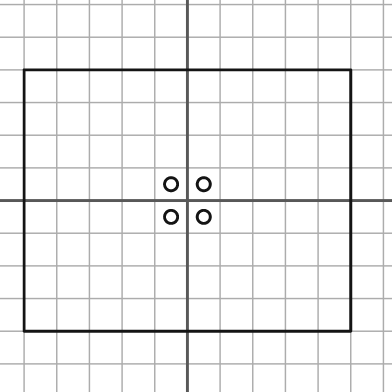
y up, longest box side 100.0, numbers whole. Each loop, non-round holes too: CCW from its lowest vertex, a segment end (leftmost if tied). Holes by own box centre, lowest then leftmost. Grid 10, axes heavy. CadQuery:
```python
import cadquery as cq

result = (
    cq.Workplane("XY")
    .moveTo(-50.0, -40.0)
    .lineTo(50.0, -40.0)
    .lineTo(50.0, 40.0)
    .lineTo(-50.0, 40.0)
    .close()
    .moveTo(-5.0, -5.0)
    .circle(2.0)
    .moveTo(5.0, -5.0)
    .circle(2.0)
    .moveTo(-5.0, 5.0)
    .circle(2.0)
    .moveTo(5.0, 5.0)
    .circle(2.0)
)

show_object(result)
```